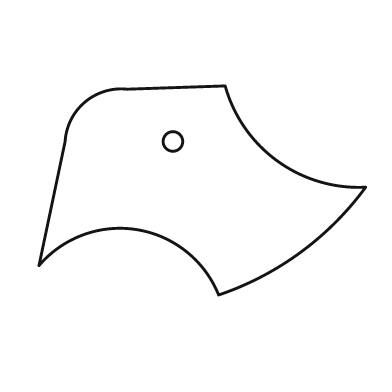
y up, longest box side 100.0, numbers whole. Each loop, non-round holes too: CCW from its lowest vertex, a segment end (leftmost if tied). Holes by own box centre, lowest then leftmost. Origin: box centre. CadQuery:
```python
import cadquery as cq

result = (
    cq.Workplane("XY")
    .moveTo(5.0, -32.0)
    .threePointArc((30.0, -19.0), (50.0, 1.0))
    .threePointArc((23.0, 9.0), (7.0, 32.0))
    .lineTo(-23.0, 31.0)
    .threePointArc((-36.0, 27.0), (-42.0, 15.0))
    .lineTo(-50.0, -23.0)
    .threePointArc((-20.0, -12.0), (5.0, -32.0))
    .close()
    .moveTo(-9.0, 15.0)
    .circle(3.0)
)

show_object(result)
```